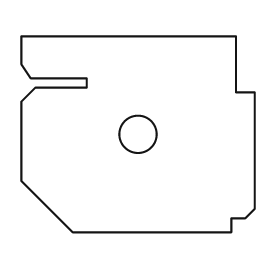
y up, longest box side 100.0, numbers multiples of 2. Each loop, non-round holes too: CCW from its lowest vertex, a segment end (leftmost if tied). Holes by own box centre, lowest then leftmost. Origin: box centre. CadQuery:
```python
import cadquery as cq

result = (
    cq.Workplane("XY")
    .moveTo(-28.0, -42.0)
    .lineTo(40.0, -42.0)
    .lineTo(40.0, -36.0)
    .lineTo(46.0, -36.0)
    .lineTo(50.0, -32.0)
    .lineTo(50.0, 18.0)
    .lineTo(42.0, 18.0)
    .lineTo(42.0, 42.0)
    .lineTo(-50.0, 42.0)
    .lineTo(-50.0, 30.0)
    .lineTo(-46.0, 24.0)
    .lineTo(-22.0, 24.0)
    .lineTo(-22.0, 20.0)
    .lineTo(-44.0, 20.0)
    .lineTo(-50.0, 14.0)
    .lineTo(-50.0, -20.0)
    .close()
    .moveTo(0.0, 0.0)
    .circle(8.0)
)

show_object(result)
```